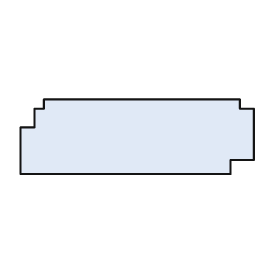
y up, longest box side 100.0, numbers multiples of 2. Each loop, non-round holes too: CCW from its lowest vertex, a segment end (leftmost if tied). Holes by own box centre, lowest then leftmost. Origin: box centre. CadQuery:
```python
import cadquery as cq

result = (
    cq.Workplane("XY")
    .moveTo(-50.0, -16.0)
    .lineTo(40.0, -16.0)
    .lineTo(40.0, -10.0)
    .lineTo(50.0, -10.0)
    .lineTo(50.0, 12.0)
    .lineTo(44.0, 12.0)
    .lineTo(44.0, 16.0)
    .lineTo(-40.0, 16.0)
    .lineTo(-40.0, 12.0)
    .lineTo(-44.0, 12.0)
    .lineTo(-44.0, 4.0)
    .lineTo(-50.0, 4.0)
    .close()
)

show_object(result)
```